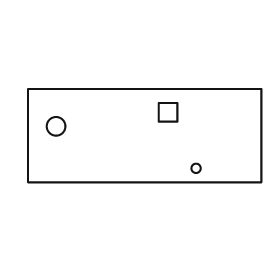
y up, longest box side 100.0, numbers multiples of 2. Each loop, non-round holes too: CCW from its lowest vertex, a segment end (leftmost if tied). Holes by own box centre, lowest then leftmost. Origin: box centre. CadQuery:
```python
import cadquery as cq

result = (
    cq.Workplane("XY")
    .moveTo(-50.0, -20.0)
    .lineTo(50.0, -20.0)
    .lineTo(50.0, 20.0)
    .lineTo(-50.0, 20.0)
    .close()
    .moveTo(22.0, -14.0)
    .circle(2.0)
    .moveTo(-38.0, 4.0)
    .circle(4.0)
    .moveTo(6.0, 6.0)
    .lineTo(14.0, 6.0)
    .lineTo(14.0, 14.0)
    .lineTo(6.0, 14.0)
    .close()
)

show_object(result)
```